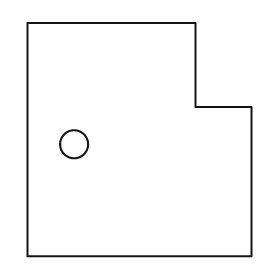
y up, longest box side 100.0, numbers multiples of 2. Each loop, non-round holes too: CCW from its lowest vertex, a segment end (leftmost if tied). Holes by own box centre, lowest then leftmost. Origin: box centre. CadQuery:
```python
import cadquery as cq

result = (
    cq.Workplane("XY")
    .moveTo(-48.0, -50.0)
    .lineTo(48.0, -50.0)
    .lineTo(48.0, 14.0)
    .lineTo(24.0, 14.0)
    .lineTo(24.0, 50.0)
    .lineTo(-48.0, 50.0)
    .close()
    .moveTo(-28.0, -2.0)
    .circle(6.0)
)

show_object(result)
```